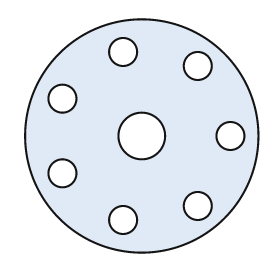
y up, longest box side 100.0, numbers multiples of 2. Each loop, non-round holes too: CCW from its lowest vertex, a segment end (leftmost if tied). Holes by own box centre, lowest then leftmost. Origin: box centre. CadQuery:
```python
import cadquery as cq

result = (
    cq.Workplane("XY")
    .moveTo(0.0, 0.0)
    .circle(50.0)
    .moveTo(-8.0, -36.0)
    .circle(6.0)
    .moveTo(24.0, -30.0)
    .circle(6.0)
    .moveTo(-34.0, -16.0)
    .circle(6.0)
    .moveTo(0.0, 0.0)
    .circle(10.0)
    .moveTo(38.0, 0.0)
    .circle(6.0)
    .moveTo(-34.0, 16.0)
    .circle(6.0)
    .moveTo(24.0, 30.0)
    .circle(6.0)
    .moveTo(-8.0, 36.0)
    .circle(6.0)
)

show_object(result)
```